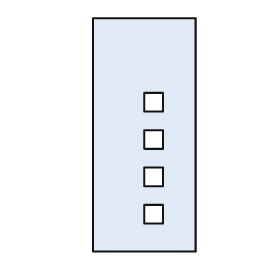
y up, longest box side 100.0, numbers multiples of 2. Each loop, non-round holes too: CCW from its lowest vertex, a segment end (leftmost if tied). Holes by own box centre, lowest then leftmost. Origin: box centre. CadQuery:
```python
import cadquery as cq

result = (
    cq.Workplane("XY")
    .moveTo(-22.0, -50.0)
    .lineTo(22.0, -50.0)
    .lineTo(22.0, 50.0)
    .lineTo(-22.0, 50.0)
    .close()
    .moveTo(0.0, -38.0)
    .lineTo(8.0, -38.0)
    .lineTo(8.0, -30.0)
    .lineTo(0.0, -30.0)
    .close()
    .moveTo(0.0, -22.0)
    .lineTo(8.0, -22.0)
    .lineTo(8.0, -14.0)
    .lineTo(0.0, -14.0)
    .close()
    .moveTo(0.0, -6.0)
    .lineTo(8.0, -6.0)
    .lineTo(8.0, 2.0)
    .lineTo(0.0, 2.0)
    .close()
    .moveTo(0.0, 10.0)
    .lineTo(8.0, 10.0)
    .lineTo(8.0, 18.0)
    .lineTo(0.0, 18.0)
    .close()
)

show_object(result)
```